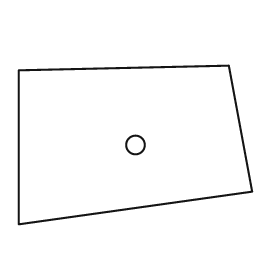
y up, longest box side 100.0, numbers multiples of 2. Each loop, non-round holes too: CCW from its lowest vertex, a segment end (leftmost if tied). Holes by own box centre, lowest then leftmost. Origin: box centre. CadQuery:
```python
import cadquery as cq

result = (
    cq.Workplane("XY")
    .moveTo(-50.0, -34.0)
    .lineTo(50.0, -20.0)
    .lineTo(40.0, 34.0)
    .lineTo(-50.0, 32.0)
    .close()
    .moveTo(0.0, 0.0)
    .circle(4.0)
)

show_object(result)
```